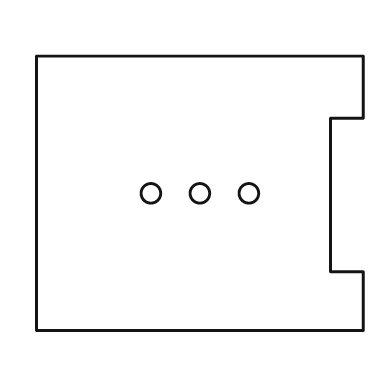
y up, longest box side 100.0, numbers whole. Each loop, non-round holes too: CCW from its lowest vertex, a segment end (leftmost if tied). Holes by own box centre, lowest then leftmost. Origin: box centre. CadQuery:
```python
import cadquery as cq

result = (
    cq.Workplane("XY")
    .moveTo(-50.0, -42.0)
    .lineTo(50.0, -42.0)
    .lineTo(50.0, -24.0)
    .lineTo(40.0, -24.0)
    .lineTo(40.0, 23.0)
    .lineTo(50.0, 23.0)
    .lineTo(50.0, 42.0)
    .lineTo(-50.0, 42.0)
    .close()
    .moveTo(-15.0, 0.0)
    .circle(3.0)
    .moveTo(0.0, 0.0)
    .circle(3.0)
    .moveTo(15.0, 0.0)
    .circle(3.0)
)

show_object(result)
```